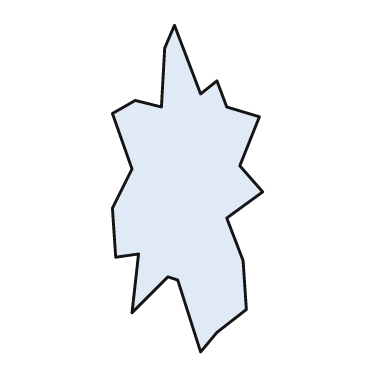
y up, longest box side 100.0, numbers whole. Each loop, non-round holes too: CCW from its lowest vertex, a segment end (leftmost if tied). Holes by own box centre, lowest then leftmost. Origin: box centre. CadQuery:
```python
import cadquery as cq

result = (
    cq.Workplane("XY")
    .moveTo(4.0, -50.0)
    .lineTo(9.0, -44.0)
    .lineTo(18.0, -37.0)
    .lineTo(17.0, -22.0)
    .lineTo(12.0, -9.0)
    .lineTo(23.0, -1.0)
    .lineTo(16.0, 7.0)
    .lineTo(22.0, 22.0)
    .lineTo(12.0, 25.0)
    .lineTo(9.0, 33.0)
    .lineTo(4.0, 29.0)
    .lineTo(-4.0, 50.0)
    .lineTo(-7.0, 43.0)
    .lineTo(-8.0, 25.0)
    .lineTo(-16.0, 27.0)
    .lineTo(-23.0, 23.0)
    .lineTo(-17.0, 6.0)
    .lineTo(-23.0, -6.0)
    .lineTo(-22.0, -21.0)
    .lineTo(-15.0, -20.0)
    .lineTo(-17.0, -38.0)
    .lineTo(-6.0, -27.0)
    .lineTo(-3.0, -28.0)
    .close()
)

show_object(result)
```